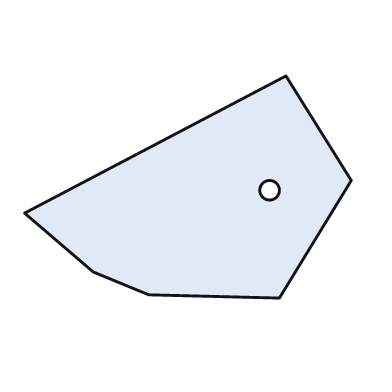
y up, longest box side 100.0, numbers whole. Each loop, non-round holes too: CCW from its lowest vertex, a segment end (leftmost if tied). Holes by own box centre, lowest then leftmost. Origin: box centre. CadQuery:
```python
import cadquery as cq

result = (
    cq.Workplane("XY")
    .moveTo(28.0, -34.0)
    .lineTo(50.0, 2.0)
    .lineTo(30.0, 34.0)
    .lineTo(-50.0, -8.0)
    .lineTo(-29.0, -26.0)
    .lineTo(-12.0, -33.0)
    .close()
    .moveTo(25.0, -1.0)
    .circle(3.0)
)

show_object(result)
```